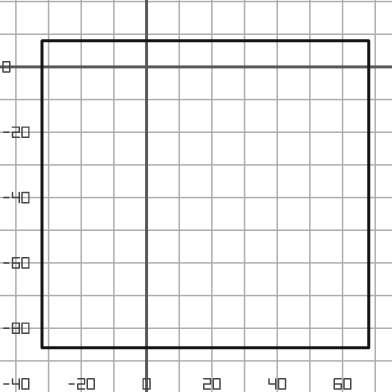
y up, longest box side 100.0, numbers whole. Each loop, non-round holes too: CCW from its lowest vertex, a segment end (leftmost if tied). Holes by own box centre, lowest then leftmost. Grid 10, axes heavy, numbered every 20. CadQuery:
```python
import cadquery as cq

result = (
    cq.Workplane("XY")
    .moveTo(-32.0, -86.0)
    .lineTo(68.0, -86.0)
    .lineTo(68.0, 8.0)
    .lineTo(-32.0, 8.0)
    .close()
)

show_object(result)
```